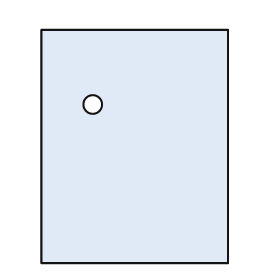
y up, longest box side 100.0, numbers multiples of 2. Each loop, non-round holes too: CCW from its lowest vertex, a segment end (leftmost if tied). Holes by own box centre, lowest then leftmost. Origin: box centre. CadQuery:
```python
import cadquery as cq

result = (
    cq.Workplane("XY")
    .moveTo(-40.0, -50.0)
    .lineTo(40.0, -50.0)
    .lineTo(40.0, 50.0)
    .lineTo(-40.0, 50.0)
    .close()
    .moveTo(-18.0, 18.0)
    .circle(4.0)
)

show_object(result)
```